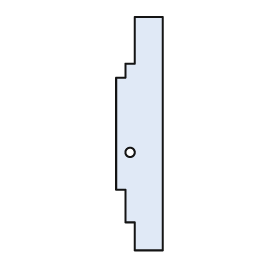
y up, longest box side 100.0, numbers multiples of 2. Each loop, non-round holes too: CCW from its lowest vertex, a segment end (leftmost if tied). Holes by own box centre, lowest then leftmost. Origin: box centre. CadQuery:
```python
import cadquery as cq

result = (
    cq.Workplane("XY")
    .moveTo(-2.0, -50.0)
    .lineTo(10.0, -50.0)
    .lineTo(10.0, 50.0)
    .lineTo(-2.0, 50.0)
    .lineTo(-2.0, 30.0)
    .lineTo(-6.0, 30.0)
    .lineTo(-6.0, 24.0)
    .lineTo(-10.0, 24.0)
    .lineTo(-10.0, -24.0)
    .lineTo(-6.0, -24.0)
    .lineTo(-6.0, -38.0)
    .lineTo(-2.0, -38.0)
    .close()
    .moveTo(-4.0, -8.0)
    .circle(2.0)
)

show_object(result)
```